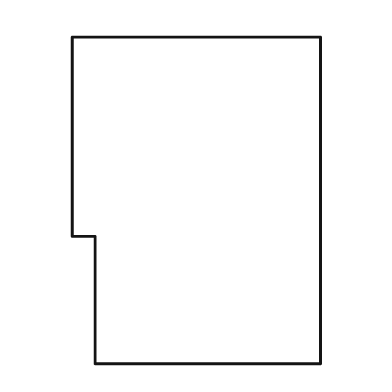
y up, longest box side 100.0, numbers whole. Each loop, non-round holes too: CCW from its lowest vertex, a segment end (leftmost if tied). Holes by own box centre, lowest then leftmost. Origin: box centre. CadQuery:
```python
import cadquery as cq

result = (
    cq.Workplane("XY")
    .moveTo(-31.0, -50.0)
    .lineTo(38.0, -50.0)
    .lineTo(38.0, 50.0)
    .lineTo(-38.0, 50.0)
    .lineTo(-38.0, -11.0)
    .lineTo(-31.0, -11.0)
    .close()
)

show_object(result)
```